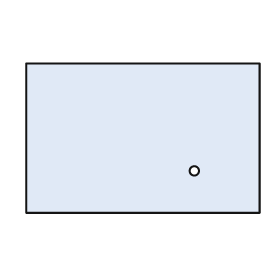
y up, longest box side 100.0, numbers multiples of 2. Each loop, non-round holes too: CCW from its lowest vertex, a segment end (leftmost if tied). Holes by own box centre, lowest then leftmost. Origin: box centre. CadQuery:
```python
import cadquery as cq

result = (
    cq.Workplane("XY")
    .moveTo(-50.0, -32.0)
    .lineTo(50.0, -32.0)
    .lineTo(50.0, 32.0)
    .lineTo(-50.0, 32.0)
    .close()
    .moveTo(22.0, -14.0)
    .circle(2.0)
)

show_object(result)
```